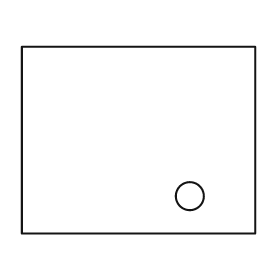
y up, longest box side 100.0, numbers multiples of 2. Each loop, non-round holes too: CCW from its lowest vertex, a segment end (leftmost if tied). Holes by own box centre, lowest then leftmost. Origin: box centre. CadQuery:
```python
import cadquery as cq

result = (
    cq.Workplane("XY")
    .moveTo(-50.0, -40.0)
    .lineTo(50.0, -40.0)
    .lineTo(50.0, 40.0)
    .lineTo(-50.0, 40.0)
    .close()
    .moveTo(22.0, -24.0)
    .circle(6.0)
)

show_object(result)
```